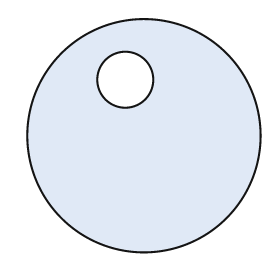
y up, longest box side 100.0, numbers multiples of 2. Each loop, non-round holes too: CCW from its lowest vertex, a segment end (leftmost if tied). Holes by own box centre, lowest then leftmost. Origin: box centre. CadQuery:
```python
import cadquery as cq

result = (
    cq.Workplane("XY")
    .moveTo(0.0, 0.0)
    .circle(50.0)
    .moveTo(-8.0, 24.0)
    .circle(12.0)
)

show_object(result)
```